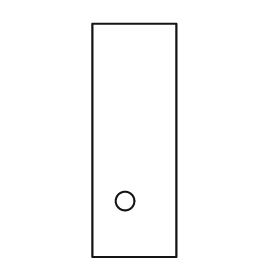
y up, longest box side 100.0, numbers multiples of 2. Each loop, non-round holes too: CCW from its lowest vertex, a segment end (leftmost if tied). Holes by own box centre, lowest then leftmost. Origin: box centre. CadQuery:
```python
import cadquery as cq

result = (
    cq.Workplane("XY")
    .moveTo(-18.0, -50.0)
    .lineTo(18.0, -50.0)
    .lineTo(18.0, 50.0)
    .lineTo(-18.0, 50.0)
    .close()
    .moveTo(-4.0, -26.0)
    .circle(4.0)
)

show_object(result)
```